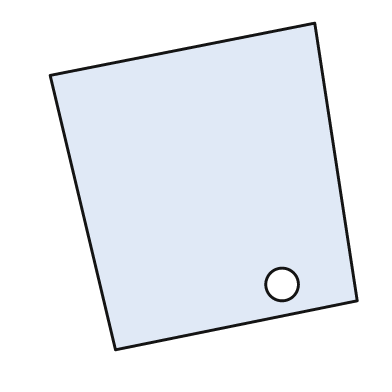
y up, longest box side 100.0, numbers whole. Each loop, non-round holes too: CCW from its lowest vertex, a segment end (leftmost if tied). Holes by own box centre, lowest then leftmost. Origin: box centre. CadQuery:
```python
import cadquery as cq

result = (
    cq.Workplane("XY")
    .moveTo(-27.0, -50.0)
    .lineTo(47.0, -35.0)
    .lineTo(34.0, 50.0)
    .lineTo(-47.0, 34.0)
    .close()
    .moveTo(24.0, -30.0)
    .circle(5.0)
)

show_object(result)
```